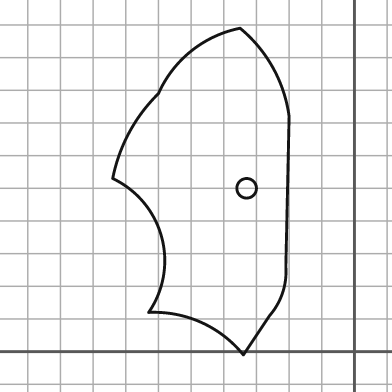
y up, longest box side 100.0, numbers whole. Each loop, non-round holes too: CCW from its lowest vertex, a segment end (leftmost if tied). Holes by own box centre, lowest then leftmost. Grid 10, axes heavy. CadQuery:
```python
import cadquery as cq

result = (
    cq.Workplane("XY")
    .moveTo(-34.0, -1.0)
    .lineTo(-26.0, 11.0)
    .threePointArc((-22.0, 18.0), (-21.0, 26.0))
    .lineTo(-20.0, 72.0)
    .threePointArc((-25.0, 87.0), (-35.0, 99.0))
    .threePointArc((-50.0, 92.0), (-60.0, 79.0))
    .threePointArc((-69.0, 67.0), (-74.0, 53.0))
    .threePointArc((-59.0, 35.0), (-63.0, 12.0))
    .threePointArc((-47.0, 9.0), (-34.0, -1.0))
    .close()
    .moveTo(-33.0, 50.0)
    .circle(3.0)
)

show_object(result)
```